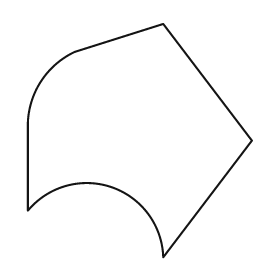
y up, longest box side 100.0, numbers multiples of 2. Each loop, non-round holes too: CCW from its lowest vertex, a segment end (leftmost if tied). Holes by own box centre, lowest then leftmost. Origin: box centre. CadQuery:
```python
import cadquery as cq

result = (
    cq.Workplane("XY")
    .moveTo(10.0, -50.0)
    .lineTo(48.0, 0.0)
    .lineTo(10.0, 50.0)
    .lineTo(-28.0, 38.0)
    .threePointArc((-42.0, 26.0), (-48.0, 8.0))
    .lineTo(-48.0, -30.0)
    .threePointArc((-12.0, -20.0), (10.0, -50.0))
    .close()
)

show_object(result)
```